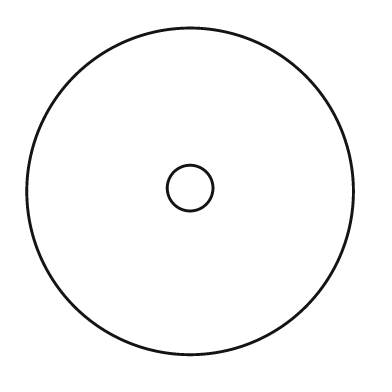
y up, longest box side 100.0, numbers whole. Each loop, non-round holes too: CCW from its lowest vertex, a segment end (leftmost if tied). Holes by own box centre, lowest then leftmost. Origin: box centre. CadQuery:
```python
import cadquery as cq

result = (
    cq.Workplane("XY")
    .moveTo(0.0, 0.0)
    .circle(50.0)
    .moveTo(0.0, 1.0)
    .circle(7.0)
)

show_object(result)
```